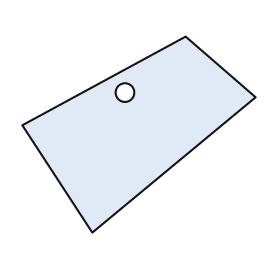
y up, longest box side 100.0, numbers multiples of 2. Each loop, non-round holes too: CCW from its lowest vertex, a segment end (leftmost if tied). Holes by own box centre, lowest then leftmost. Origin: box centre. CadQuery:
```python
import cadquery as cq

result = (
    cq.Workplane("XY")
    .moveTo(-20.0, -42.0)
    .lineTo(50.0, 16.0)
    .lineTo(20.0, 42.0)
    .lineTo(-50.0, 4.0)
    .close()
    .moveTo(-6.0, 18.0)
    .circle(4.0)
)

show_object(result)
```